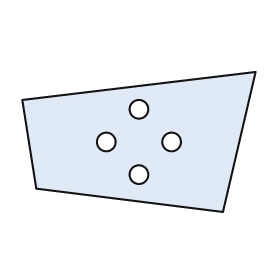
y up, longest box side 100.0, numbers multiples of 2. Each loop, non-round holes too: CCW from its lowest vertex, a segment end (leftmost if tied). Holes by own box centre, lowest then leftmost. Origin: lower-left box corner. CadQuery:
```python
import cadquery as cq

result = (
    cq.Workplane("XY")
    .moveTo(86.0, 0.0)
    .lineTo(100.0, 60.0)
    .lineTo(0.0, 48.0)
    .lineTo(6.0, 10.0)
    .close()
    .moveTo(50.0, 16.0)
    .circle(4.0)
    .moveTo(36.0, 30.0)
    .circle(4.0)
    .moveTo(64.0, 30.0)
    .circle(4.0)
    .moveTo(50.0, 44.0)
    .circle(4.0)
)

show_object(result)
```